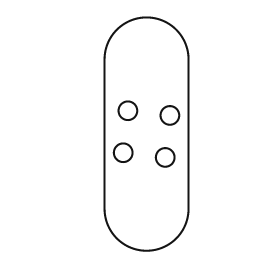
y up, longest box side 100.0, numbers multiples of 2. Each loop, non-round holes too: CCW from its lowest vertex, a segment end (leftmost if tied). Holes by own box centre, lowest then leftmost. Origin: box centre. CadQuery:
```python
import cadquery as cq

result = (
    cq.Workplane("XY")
    .moveTo(-18.0, -32.0)
    .threePointArc((0.0, -50.0), (18.0, -32.0))
    .lineTo(18.0, 32.0)
    .threePointArc((0.0, 50.0), (-18.0, 32.0))
    .close()
    .moveTo(8.0, -10.0)
    .circle(4.0)
    .moveTo(-10.0, -8.0)
    .circle(4.0)
    .moveTo(10.0, 8.0)
    .circle(4.0)
    .moveTo(-8.0, 10.0)
    .circle(4.0)
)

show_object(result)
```